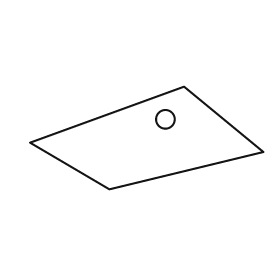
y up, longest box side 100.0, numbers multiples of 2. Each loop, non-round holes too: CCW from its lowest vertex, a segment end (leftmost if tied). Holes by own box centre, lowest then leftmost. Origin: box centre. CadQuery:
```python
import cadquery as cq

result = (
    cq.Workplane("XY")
    .moveTo(-16.0, -22.0)
    .lineTo(50.0, -6.0)
    .lineTo(16.0, 22.0)
    .lineTo(-50.0, -2.0)
    .close()
    .moveTo(8.0, 8.0)
    .circle(4.0)
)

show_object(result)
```